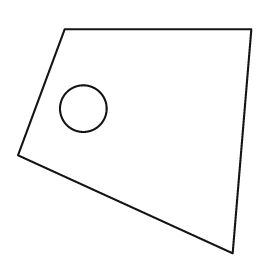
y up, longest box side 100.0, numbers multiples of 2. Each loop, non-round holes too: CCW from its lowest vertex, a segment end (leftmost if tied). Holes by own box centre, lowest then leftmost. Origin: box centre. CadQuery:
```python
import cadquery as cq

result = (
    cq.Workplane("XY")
    .moveTo(42.0, -48.0)
    .lineTo(50.0, 48.0)
    .lineTo(-30.0, 48.0)
    .lineTo(-50.0, -6.0)
    .close()
    .moveTo(-22.0, 14.0)
    .circle(10.0)
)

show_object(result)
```